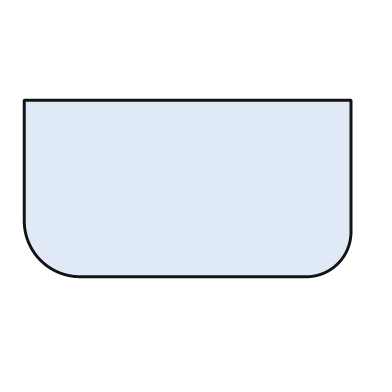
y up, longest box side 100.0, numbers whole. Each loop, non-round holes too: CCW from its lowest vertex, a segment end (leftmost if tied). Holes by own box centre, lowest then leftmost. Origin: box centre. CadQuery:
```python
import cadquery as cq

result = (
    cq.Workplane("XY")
    .moveTo(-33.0, -27.0)
    .lineTo(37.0, -27.0)
    .threePointArc((46.0, -23.0), (50.0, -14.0))
    .lineTo(50.0, 27.0)
    .lineTo(-50.0, 27.0)
    .lineTo(-50.0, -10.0)
    .threePointArc((-45.0, -22.0), (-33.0, -27.0))
    .close()
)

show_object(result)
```